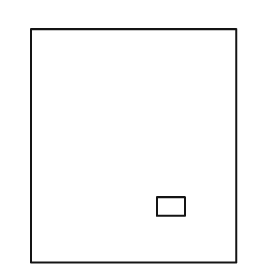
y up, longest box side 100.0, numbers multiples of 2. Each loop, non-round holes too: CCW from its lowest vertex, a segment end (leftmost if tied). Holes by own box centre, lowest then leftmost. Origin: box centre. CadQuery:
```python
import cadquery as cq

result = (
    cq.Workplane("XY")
    .moveTo(-44.0, -50.0)
    .lineTo(44.0, -50.0)
    .lineTo(44.0, 50.0)
    .lineTo(-44.0, 50.0)
    .close()
    .moveTo(10.0, -30.0)
    .lineTo(22.0, -30.0)
    .lineTo(22.0, -22.0)
    .lineTo(10.0, -22.0)
    .close()
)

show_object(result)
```